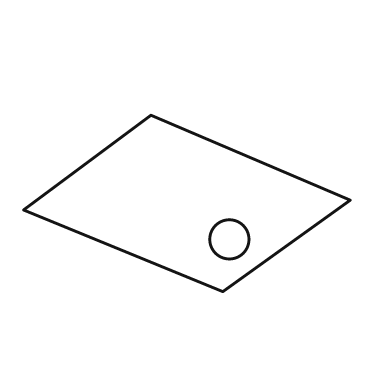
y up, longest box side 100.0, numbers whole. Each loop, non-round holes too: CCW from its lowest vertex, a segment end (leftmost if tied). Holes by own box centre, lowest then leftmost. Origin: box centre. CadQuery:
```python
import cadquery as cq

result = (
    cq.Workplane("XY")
    .moveTo(11.0, -27.0)
    .lineTo(50.0, 1.0)
    .lineTo(-11.0, 27.0)
    .lineTo(-50.0, -2.0)
    .close()
    .moveTo(13.0, -11.0)
    .circle(6.0)
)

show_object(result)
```